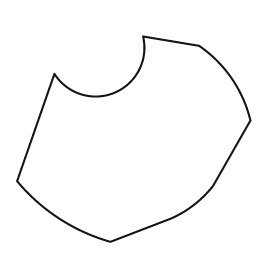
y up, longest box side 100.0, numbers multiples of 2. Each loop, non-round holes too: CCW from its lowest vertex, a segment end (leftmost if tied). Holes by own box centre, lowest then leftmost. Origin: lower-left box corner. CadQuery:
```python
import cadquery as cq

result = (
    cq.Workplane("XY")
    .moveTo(40.0, 0.0)
    .lineTo(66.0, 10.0)
    .threePointArc((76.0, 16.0), (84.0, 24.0))
    .lineTo(100.0, 52.0)
    .threePointArc((92.0, 70.0), (78.0, 84.0))
    .lineTo(54.0, 88.0)
    .threePointArc((42.0, 64.0), (16.0, 72.0))
    .lineTo(0.0, 26.0)
    .threePointArc((18.0, 10.0), (40.0, 0.0))
    .close()
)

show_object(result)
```